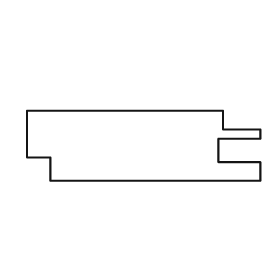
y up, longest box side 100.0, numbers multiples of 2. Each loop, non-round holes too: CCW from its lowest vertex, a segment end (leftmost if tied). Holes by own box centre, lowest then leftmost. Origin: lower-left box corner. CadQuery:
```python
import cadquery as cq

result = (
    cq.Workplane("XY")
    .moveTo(10.0, 0.0)
    .lineTo(100.0, 0.0)
    .lineTo(100.0, 8.0)
    .lineTo(82.0, 8.0)
    .lineTo(82.0, 18.0)
    .lineTo(100.0, 18.0)
    .lineTo(100.0, 22.0)
    .lineTo(84.0, 22.0)
    .lineTo(84.0, 30.0)
    .lineTo(0.0, 30.0)
    .lineTo(0.0, 10.0)
    .lineTo(10.0, 10.0)
    .close()
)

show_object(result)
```